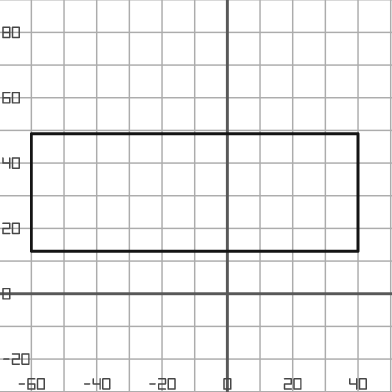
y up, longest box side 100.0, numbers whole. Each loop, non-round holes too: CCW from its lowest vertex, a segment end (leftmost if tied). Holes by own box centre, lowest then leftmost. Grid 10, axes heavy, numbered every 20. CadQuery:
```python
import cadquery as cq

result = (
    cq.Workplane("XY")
    .moveTo(-60.0, 13.0)
    .lineTo(40.0, 13.0)
    .lineTo(40.0, 49.0)
    .lineTo(-60.0, 49.0)
    .close()
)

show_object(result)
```